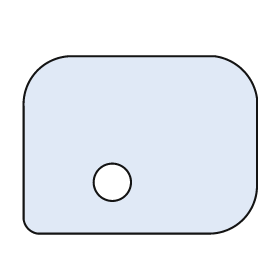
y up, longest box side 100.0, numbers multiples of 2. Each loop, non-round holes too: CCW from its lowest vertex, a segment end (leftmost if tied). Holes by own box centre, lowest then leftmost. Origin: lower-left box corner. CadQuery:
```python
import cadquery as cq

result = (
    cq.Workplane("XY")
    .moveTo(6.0, 0.0)
    .lineTo(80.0, 0.0)
    .threePointArc((94.0, 6.0), (100.0, 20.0))
    .lineTo(100.0, 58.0)
    .threePointArc((94.0, 70.0), (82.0, 76.0))
    .lineTo(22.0, 76.0)
    .threePointArc((6.0, 70.0), (0.0, 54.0))
    .lineTo(0.0, 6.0)
    .threePointArc((2.0, 2.0), (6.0, 0.0))
    .close()
    .moveTo(38.0, 22.0)
    .circle(8.0)
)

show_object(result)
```